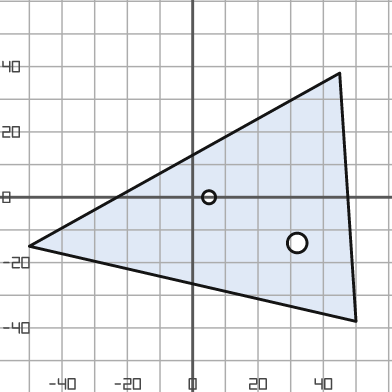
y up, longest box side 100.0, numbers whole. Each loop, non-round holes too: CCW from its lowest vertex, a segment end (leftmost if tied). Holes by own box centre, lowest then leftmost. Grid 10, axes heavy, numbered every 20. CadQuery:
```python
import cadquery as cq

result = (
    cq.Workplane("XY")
    .moveTo(50.0, -38.0)
    .lineTo(45.0, 38.0)
    .lineTo(-50.0, -15.0)
    .close()
    .moveTo(32.0, -14.0)
    .circle(3.0)
    .moveTo(5.0, 0.0)
    .circle(2.0)
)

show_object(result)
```